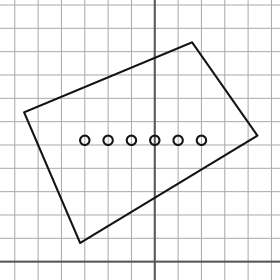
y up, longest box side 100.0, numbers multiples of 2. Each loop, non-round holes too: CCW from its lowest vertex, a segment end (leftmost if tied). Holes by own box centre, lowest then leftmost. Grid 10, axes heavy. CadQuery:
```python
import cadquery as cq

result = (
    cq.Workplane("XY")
    .moveTo(-32.0, 8.0)
    .lineTo(44.0, 54.0)
    .lineTo(16.0, 94.0)
    .lineTo(-56.0, 64.0)
    .close()
    .moveTo(-30.0, 52.0)
    .circle(2.0)
    .moveTo(-20.0, 52.0)
    .circle(2.0)
    .moveTo(-10.0, 52.0)
    .circle(2.0)
    .moveTo(0.0, 52.0)
    .circle(2.0)
    .moveTo(10.0, 52.0)
    .circle(2.0)
    .moveTo(20.0, 52.0)
    .circle(2.0)
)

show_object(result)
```